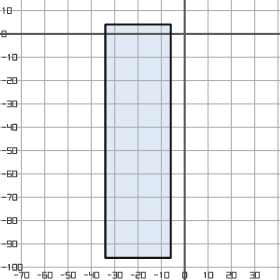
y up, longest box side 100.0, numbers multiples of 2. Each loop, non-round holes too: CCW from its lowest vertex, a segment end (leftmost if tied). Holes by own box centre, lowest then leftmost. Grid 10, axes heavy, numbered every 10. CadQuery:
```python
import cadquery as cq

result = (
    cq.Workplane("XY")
    .moveTo(-34.0, -96.0)
    .lineTo(-6.0, -96.0)
    .lineTo(-6.0, 4.0)
    .lineTo(-34.0, 4.0)
    .close()
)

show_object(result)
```